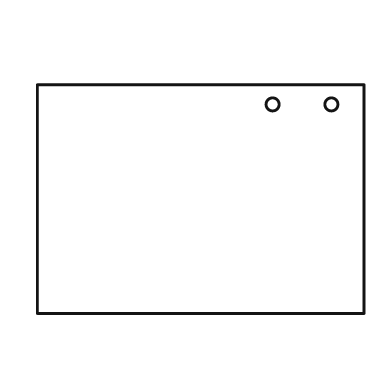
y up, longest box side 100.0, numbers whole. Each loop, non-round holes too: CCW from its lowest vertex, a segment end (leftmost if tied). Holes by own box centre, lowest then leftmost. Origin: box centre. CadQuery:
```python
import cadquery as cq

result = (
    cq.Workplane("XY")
    .moveTo(-50.0, -35.0)
    .lineTo(50.0, -35.0)
    .lineTo(50.0, 35.0)
    .lineTo(-50.0, 35.0)
    .close()
    .moveTo(22.0, 29.0)
    .circle(2.0)
    .moveTo(40.0, 29.0)
    .circle(2.0)
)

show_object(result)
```